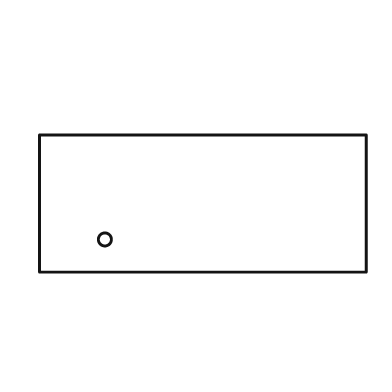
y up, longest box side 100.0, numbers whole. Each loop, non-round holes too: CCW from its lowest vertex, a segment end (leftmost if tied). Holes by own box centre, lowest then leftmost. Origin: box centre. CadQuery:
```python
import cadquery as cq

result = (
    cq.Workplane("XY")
    .moveTo(-50.0, -21.0)
    .lineTo(50.0, -21.0)
    .lineTo(50.0, 21.0)
    .lineTo(-50.0, 21.0)
    .close()
    .moveTo(-30.0, -11.0)
    .circle(2.0)
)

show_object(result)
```